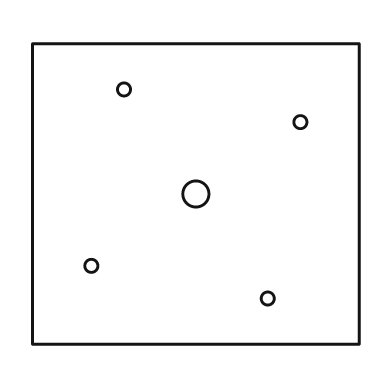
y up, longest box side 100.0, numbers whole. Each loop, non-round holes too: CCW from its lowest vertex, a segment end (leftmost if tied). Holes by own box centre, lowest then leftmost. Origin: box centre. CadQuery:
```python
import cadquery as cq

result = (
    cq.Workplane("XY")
    .moveTo(-50.0, -46.0)
    .lineTo(50.0, -46.0)
    .lineTo(50.0, 46.0)
    .lineTo(-50.0, 46.0)
    .close()
    .moveTo(22.0, -32.0)
    .circle(2.0)
    .moveTo(-32.0, -22.0)
    .circle(2.0)
    .moveTo(0.0, 0.0)
    .circle(4.0)
    .moveTo(32.0, 22.0)
    .circle(2.0)
    .moveTo(-22.0, 32.0)
    .circle(2.0)
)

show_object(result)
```